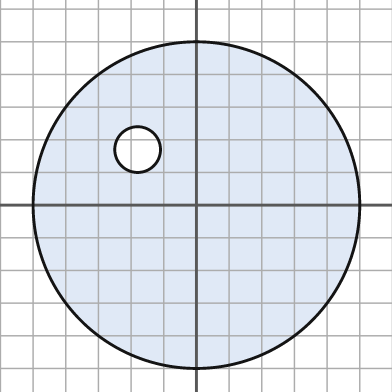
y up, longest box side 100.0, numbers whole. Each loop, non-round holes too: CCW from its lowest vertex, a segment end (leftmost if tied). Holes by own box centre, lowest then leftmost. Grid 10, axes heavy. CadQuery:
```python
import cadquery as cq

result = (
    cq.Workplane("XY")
    .moveTo(0.0, 0.0)
    .circle(50.0)
    .moveTo(-18.0, 17.0)
    .circle(7.0)
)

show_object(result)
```